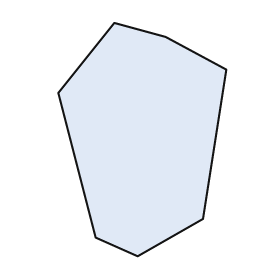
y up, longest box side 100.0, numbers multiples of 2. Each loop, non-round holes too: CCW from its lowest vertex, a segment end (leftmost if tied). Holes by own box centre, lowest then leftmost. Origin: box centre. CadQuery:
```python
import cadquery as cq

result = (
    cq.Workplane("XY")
    .moveTo(-2.0, -50.0)
    .lineTo(26.0, -34.0)
    .lineTo(36.0, 30.0)
    .lineTo(10.0, 44.0)
    .lineTo(-12.0, 50.0)
    .lineTo(-36.0, 20.0)
    .lineTo(-20.0, -42.0)
    .close()
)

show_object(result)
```